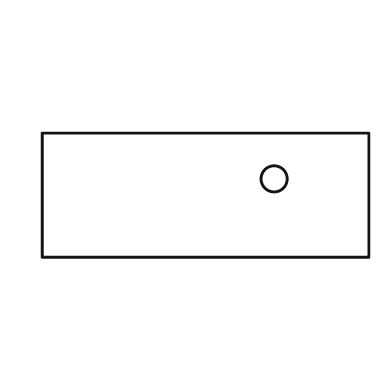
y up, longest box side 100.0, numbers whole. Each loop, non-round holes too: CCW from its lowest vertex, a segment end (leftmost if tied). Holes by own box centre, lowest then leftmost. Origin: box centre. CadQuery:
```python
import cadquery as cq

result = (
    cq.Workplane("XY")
    .moveTo(-50.0, -19.0)
    .lineTo(50.0, -19.0)
    .lineTo(50.0, 19.0)
    .lineTo(-50.0, 19.0)
    .close()
    .moveTo(21.0, 5.0)
    .circle(4.0)
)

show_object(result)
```